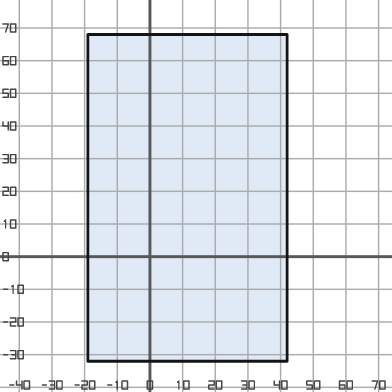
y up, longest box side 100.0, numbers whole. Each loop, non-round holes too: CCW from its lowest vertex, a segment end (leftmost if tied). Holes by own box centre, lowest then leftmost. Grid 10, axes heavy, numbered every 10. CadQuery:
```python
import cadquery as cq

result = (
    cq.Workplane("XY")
    .moveTo(-19.0, -32.0)
    .lineTo(42.0, -32.0)
    .lineTo(42.0, 68.0)
    .lineTo(-19.0, 68.0)
    .close()
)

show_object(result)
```